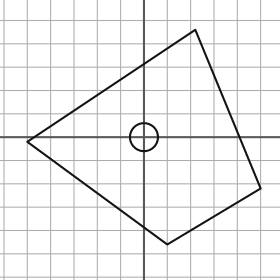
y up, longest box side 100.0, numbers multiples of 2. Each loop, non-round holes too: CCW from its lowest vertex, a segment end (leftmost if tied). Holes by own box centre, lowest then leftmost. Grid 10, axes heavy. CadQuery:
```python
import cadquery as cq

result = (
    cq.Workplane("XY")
    .moveTo(10.0, -46.0)
    .lineTo(50.0, -22.0)
    .lineTo(22.0, 46.0)
    .lineTo(-50.0, -2.0)
    .close()
    .moveTo(0.0, 0.0)
    .circle(6.0)
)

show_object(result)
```